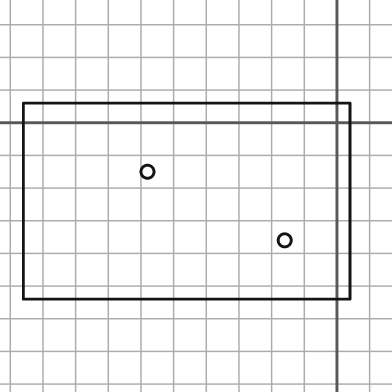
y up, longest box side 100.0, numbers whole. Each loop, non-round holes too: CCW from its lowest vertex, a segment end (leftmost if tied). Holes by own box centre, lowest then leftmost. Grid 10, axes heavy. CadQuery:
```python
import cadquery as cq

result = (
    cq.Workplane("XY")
    .moveTo(-96.0, -54.0)
    .lineTo(4.0, -54.0)
    .lineTo(4.0, 6.0)
    .lineTo(-96.0, 6.0)
    .close()
    .moveTo(-16.0, -36.0)
    .circle(2.0)
    .moveTo(-58.0, -15.0)
    .circle(2.0)
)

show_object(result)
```